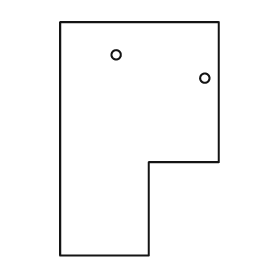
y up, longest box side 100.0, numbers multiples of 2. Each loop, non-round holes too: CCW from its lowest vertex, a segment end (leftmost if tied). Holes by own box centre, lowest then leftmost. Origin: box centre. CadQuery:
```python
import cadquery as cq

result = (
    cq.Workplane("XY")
    .moveTo(-34.0, -50.0)
    .lineTo(4.0, -50.0)
    .lineTo(4.0, -10.0)
    .lineTo(34.0, -10.0)
    .lineTo(34.0, 50.0)
    .lineTo(-34.0, 50.0)
    .close()
    .moveTo(28.0, 26.0)
    .circle(2.0)
    .moveTo(-10.0, 36.0)
    .circle(2.0)
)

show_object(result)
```